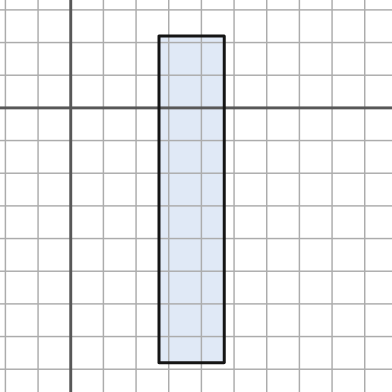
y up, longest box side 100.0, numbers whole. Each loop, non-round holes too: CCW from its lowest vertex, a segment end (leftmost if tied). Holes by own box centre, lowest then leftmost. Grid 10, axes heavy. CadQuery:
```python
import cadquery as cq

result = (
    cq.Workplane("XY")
    .moveTo(27.0, -78.0)
    .lineTo(47.0, -78.0)
    .lineTo(47.0, 22.0)
    .lineTo(27.0, 22.0)
    .close()
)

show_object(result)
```